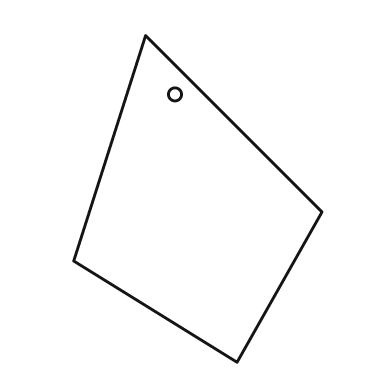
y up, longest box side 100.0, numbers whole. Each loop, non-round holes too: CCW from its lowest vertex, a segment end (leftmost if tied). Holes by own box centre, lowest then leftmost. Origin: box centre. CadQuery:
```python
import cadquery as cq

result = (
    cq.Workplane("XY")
    .moveTo(12.0, -50.0)
    .lineTo(38.0, -4.0)
    .lineTo(-16.0, 50.0)
    .lineTo(-38.0, -19.0)
    .close()
    .moveTo(-7.0, 32.0)
    .circle(2.0)
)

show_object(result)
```